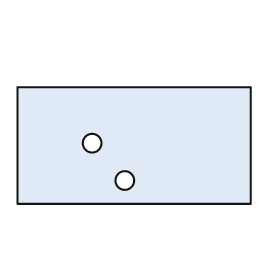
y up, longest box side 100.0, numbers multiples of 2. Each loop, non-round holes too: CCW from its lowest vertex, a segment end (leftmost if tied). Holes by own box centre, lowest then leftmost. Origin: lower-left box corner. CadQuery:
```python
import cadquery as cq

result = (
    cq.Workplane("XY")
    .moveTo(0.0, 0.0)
    .lineTo(100.0, 0.0)
    .lineTo(100.0, 50.0)
    .lineTo(0.0, 50.0)
    .close()
    .moveTo(46.0, 10.0)
    .circle(4.0)
    .moveTo(32.0, 26.0)
    .circle(4.0)
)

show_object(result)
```